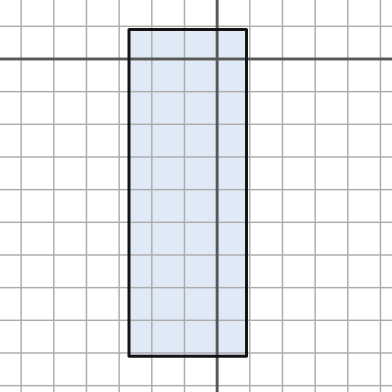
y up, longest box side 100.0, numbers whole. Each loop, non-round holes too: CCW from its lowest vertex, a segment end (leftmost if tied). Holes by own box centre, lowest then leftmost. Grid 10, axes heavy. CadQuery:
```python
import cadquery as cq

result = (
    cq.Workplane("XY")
    .moveTo(-27.0, -91.0)
    .lineTo(9.0, -91.0)
    .lineTo(9.0, 9.0)
    .lineTo(-27.0, 9.0)
    .close()
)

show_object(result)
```